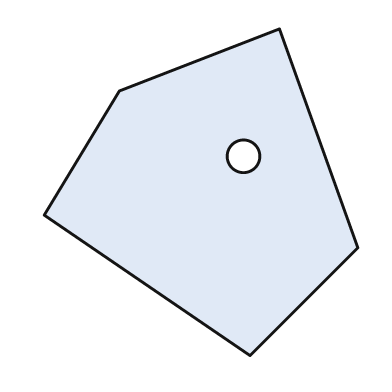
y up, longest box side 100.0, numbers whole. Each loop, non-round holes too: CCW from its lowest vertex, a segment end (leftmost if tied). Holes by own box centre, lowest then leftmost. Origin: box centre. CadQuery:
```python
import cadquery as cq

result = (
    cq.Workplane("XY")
    .moveTo(15.0, -50.0)
    .lineTo(48.0, -17.0)
    .lineTo(24.0, 50.0)
    .lineTo(-25.0, 31.0)
    .lineTo(-48.0, -7.0)
    .close()
    .moveTo(13.0, 11.0)
    .circle(5.0)
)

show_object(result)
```